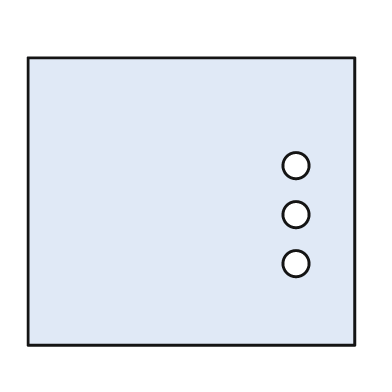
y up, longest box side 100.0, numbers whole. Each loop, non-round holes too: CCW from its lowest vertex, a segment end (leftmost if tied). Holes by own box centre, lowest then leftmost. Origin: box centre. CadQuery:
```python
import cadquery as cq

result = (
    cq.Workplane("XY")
    .moveTo(-50.0, -44.0)
    .lineTo(50.0, -44.0)
    .lineTo(50.0, 44.0)
    .lineTo(-50.0, 44.0)
    .close()
    .moveTo(32.0, -19.0)
    .circle(4.0)
    .moveTo(32.0, -4.0)
    .circle(4.0)
    .moveTo(32.0, 11.0)
    .circle(4.0)
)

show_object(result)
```